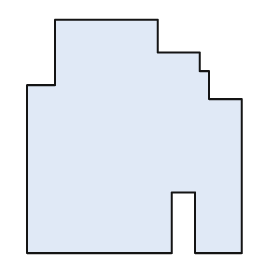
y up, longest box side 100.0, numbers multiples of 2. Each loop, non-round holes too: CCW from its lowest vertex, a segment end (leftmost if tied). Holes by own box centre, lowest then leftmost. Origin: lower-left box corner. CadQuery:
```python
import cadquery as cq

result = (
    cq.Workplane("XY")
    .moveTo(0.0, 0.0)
    .lineTo(62.0, 0.0)
    .lineTo(62.0, 26.0)
    .lineTo(72.0, 26.0)
    .lineTo(72.0, 0.0)
    .lineTo(92.0, 0.0)
    .lineTo(92.0, 66.0)
    .lineTo(78.0, 66.0)
    .lineTo(78.0, 78.0)
    .lineTo(74.0, 78.0)
    .lineTo(74.0, 86.0)
    .lineTo(56.0, 86.0)
    .lineTo(56.0, 100.0)
    .lineTo(12.0, 100.0)
    .lineTo(12.0, 72.0)
    .lineTo(0.0, 72.0)
    .close()
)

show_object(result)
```